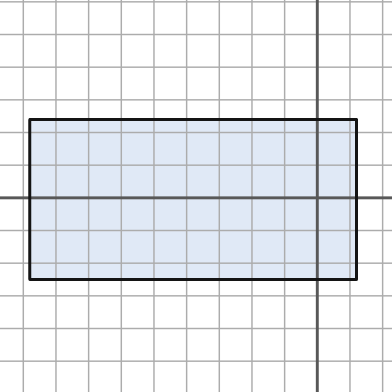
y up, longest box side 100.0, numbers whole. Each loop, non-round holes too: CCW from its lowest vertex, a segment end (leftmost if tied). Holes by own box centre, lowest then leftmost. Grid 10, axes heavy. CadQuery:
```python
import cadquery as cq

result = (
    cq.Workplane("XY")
    .moveTo(-88.0, -25.0)
    .lineTo(12.0, -25.0)
    .lineTo(12.0, 24.0)
    .lineTo(-88.0, 24.0)
    .close()
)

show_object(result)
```